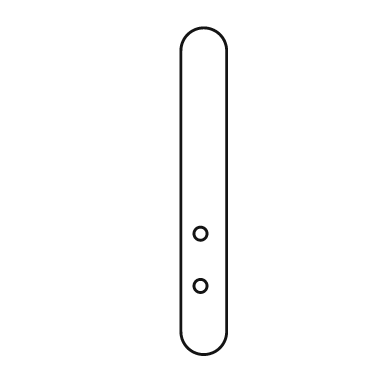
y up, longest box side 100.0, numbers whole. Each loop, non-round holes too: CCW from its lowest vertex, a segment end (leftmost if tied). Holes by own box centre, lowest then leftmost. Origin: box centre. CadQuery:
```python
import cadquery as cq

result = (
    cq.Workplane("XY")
    .moveTo(-7.0, -43.0)
    .threePointArc((0.0, -50.0), (7.0, -43.0))
    .lineTo(7.0, 43.0)
    .threePointArc((0.0, 50.0), (-7.0, 43.0))
    .close()
    .moveTo(-1.0, -29.0)
    .circle(2.0)
    .moveTo(-1.0, -13.0)
    .circle(2.0)
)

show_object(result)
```